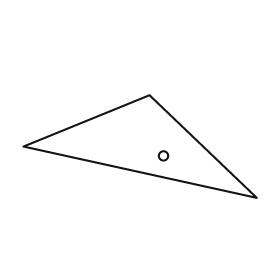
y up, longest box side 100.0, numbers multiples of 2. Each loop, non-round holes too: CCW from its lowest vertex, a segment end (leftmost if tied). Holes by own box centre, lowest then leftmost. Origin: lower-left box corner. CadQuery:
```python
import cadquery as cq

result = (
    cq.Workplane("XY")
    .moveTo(100.0, 0.0)
    .lineTo(54.0, 44.0)
    .lineTo(0.0, 22.0)
    .close()
    .moveTo(60.0, 18.0)
    .circle(2.0)
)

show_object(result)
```